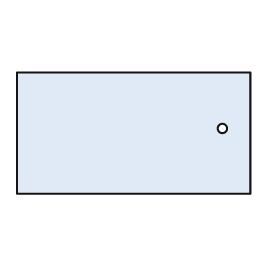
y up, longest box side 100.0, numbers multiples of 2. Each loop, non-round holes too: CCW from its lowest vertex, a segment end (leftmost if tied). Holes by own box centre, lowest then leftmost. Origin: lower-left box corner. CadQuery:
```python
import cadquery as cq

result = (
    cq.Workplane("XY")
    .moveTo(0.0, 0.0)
    .lineTo(100.0, 0.0)
    .lineTo(100.0, 52.0)
    .lineTo(0.0, 52.0)
    .close()
    .moveTo(88.0, 28.0)
    .circle(2.0)
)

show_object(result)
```